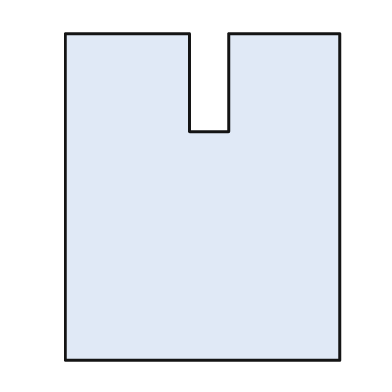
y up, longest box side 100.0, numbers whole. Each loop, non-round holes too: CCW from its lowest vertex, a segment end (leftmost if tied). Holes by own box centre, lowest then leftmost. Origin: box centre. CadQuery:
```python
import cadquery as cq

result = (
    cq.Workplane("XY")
    .moveTo(-42.0, -50.0)
    .lineTo(42.0, -50.0)
    .lineTo(42.0, 50.0)
    .lineTo(8.0, 50.0)
    .lineTo(8.0, 20.0)
    .lineTo(-4.0, 20.0)
    .lineTo(-4.0, 50.0)
    .lineTo(-42.0, 50.0)
    .close()
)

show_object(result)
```